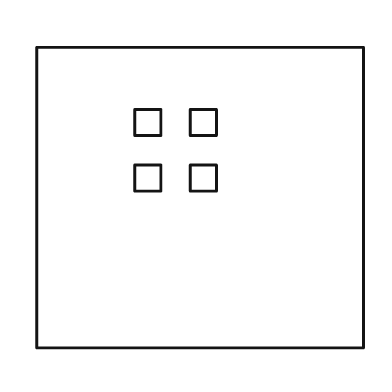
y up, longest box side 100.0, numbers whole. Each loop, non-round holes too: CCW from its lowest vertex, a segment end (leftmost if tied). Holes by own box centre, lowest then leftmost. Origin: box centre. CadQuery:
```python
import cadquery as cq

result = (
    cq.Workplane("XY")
    .moveTo(-50.0, -46.0)
    .lineTo(50.0, -46.0)
    .lineTo(50.0, 46.0)
    .lineTo(-50.0, 46.0)
    .close()
    .moveTo(-20.0, 2.0)
    .lineTo(-12.0, 2.0)
    .lineTo(-12.0, 10.0)
    .lineTo(-20.0, 10.0)
    .close()
    .moveTo(-3.0, 2.0)
    .lineTo(5.0, 2.0)
    .lineTo(5.0, 10.0)
    .lineTo(-3.0, 10.0)
    .close()
    .moveTo(-20.0, 19.0)
    .lineTo(-12.0, 19.0)
    .lineTo(-12.0, 27.0)
    .lineTo(-20.0, 27.0)
    .close()
    .moveTo(-3.0, 19.0)
    .lineTo(5.0, 19.0)
    .lineTo(5.0, 27.0)
    .lineTo(-3.0, 27.0)
    .close()
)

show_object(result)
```